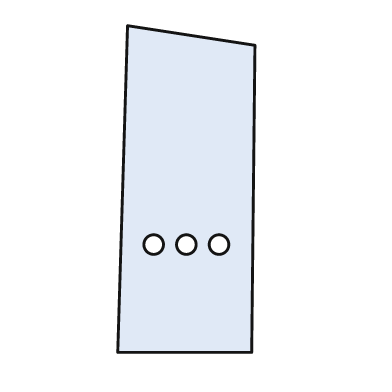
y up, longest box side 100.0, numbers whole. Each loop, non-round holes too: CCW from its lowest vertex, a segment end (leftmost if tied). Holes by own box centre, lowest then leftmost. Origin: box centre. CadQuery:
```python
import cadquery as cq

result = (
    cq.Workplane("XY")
    .moveTo(-21.0, -50.0)
    .lineTo(20.0, -50.0)
    .lineTo(21.0, 44.0)
    .lineTo(-18.0, 50.0)
    .close()
    .moveTo(-10.0, -17.0)
    .circle(3.0)
    .moveTo(0.0, -17.0)
    .circle(3.0)
    .moveTo(10.0, -17.0)
    .circle(3.0)
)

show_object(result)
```